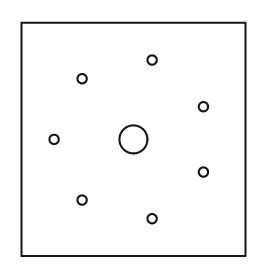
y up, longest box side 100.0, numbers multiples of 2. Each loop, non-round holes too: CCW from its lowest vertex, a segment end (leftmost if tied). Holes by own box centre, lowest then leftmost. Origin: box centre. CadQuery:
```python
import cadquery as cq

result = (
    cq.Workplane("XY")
    .moveTo(-48.0, -50.0)
    .lineTo(48.0, -50.0)
    .lineTo(48.0, 50.0)
    .lineTo(-48.0, 50.0)
    .close()
    .moveTo(8.0, -34.0)
    .circle(2.0)
    .moveTo(-22.0, -26.0)
    .circle(2.0)
    .moveTo(30.0, -14.0)
    .circle(2.0)
    .moveTo(-34.0, 0.0)
    .circle(2.0)
    .moveTo(0.0, 0.0)
    .circle(6.0)
    .moveTo(30.0, 14.0)
    .circle(2.0)
    .moveTo(-22.0, 26.0)
    .circle(2.0)
    .moveTo(8.0, 34.0)
    .circle(2.0)
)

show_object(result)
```